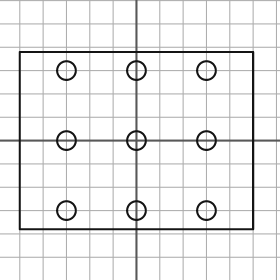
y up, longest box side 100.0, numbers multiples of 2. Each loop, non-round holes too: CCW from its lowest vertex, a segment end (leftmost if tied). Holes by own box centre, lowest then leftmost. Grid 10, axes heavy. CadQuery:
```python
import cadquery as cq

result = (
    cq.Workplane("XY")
    .moveTo(-50.0, -38.0)
    .lineTo(50.0, -38.0)
    .lineTo(50.0, 38.0)
    .lineTo(-50.0, 38.0)
    .close()
    .moveTo(-30.0, -30.0)
    .circle(4.0)
    .moveTo(0.0, -30.0)
    .circle(4.0)
    .moveTo(30.0, -30.0)
    .circle(4.0)
    .moveTo(-30.0, 0.0)
    .circle(4.0)
    .moveTo(0.0, 0.0)
    .circle(4.0)
    .moveTo(30.0, 0.0)
    .circle(4.0)
    .moveTo(-30.0, 30.0)
    .circle(4.0)
    .moveTo(0.0, 30.0)
    .circle(4.0)
    .moveTo(30.0, 30.0)
    .circle(4.0)
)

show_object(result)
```